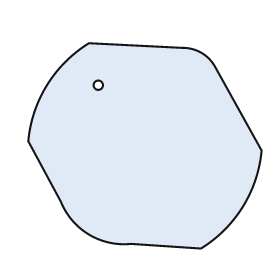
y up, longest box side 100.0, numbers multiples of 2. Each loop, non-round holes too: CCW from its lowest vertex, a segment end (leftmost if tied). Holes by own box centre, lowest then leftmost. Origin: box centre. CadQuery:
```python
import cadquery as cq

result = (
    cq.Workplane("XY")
    .moveTo(24.0, -44.0)
    .threePointArc((42.0, -26.0), (50.0, -2.0))
    .lineTo(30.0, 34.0)
    .threePointArc((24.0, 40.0), (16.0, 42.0))
    .lineTo(-24.0, 44.0)
    .threePointArc((-42.0, 26.0), (-50.0, 2.0))
    .lineTo(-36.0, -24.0)
    .threePointArc((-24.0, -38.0), (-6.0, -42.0))
    .close()
    .moveTo(-20.0, 26.0)
    .circle(2.0)
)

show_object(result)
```